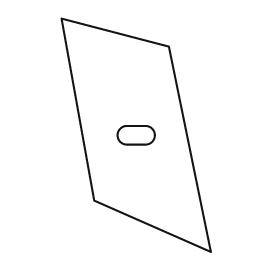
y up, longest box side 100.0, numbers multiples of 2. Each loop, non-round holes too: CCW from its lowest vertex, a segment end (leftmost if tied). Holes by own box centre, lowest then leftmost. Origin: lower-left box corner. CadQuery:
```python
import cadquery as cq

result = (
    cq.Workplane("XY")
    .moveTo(64.0, 0.0)
    .lineTo(46.0, 88.0)
    .lineTo(0.0, 100.0)
    .lineTo(14.0, 22.0)
    .close()
    .moveTo(28.0, 46.0)
    .lineTo(36.0, 46.0)
    .threePointArc((40.0, 50.0), (36.0, 54.0))
    .lineTo(28.0, 54.0)
    .threePointArc((24.0, 50.0), (28.0, 46.0))
    .close()
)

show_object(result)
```